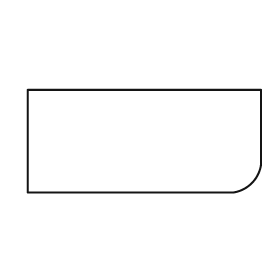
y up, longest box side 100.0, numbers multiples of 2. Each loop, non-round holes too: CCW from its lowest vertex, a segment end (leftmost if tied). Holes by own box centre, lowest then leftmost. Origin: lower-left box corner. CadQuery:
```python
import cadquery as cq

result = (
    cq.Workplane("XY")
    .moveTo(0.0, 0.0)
    .lineTo(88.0, 0.0)
    .threePointArc((96.0, 4.0), (100.0, 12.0))
    .lineTo(100.0, 44.0)
    .lineTo(0.0, 44.0)
    .close()
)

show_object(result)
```